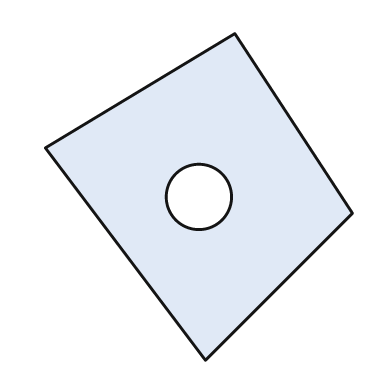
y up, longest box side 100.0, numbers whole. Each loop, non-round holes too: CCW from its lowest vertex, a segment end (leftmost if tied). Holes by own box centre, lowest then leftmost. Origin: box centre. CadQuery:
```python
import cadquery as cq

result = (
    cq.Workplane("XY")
    .moveTo(2.0, -50.0)
    .lineTo(47.0, -5.0)
    .lineTo(11.0, 50.0)
    .lineTo(-47.0, 15.0)
    .close()
    .moveTo(0.0, 0.0)
    .circle(10.0)
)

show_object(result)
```